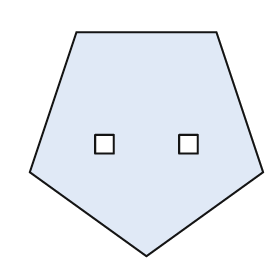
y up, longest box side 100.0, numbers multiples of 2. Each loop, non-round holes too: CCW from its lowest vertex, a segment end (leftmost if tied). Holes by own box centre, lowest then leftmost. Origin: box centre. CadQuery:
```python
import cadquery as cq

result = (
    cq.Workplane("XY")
    .moveTo(0.0, -48.0)
    .lineTo(50.0, -12.0)
    .lineTo(30.0, 48.0)
    .lineTo(-30.0, 48.0)
    .lineTo(-50.0, -12.0)
    .close()
    .moveTo(-22.0, -4.0)
    .lineTo(-14.0, -4.0)
    .lineTo(-14.0, 4.0)
    .lineTo(-22.0, 4.0)
    .close()
    .moveTo(14.0, -4.0)
    .lineTo(22.0, -4.0)
    .lineTo(22.0, 4.0)
    .lineTo(14.0, 4.0)
    .close()
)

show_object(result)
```